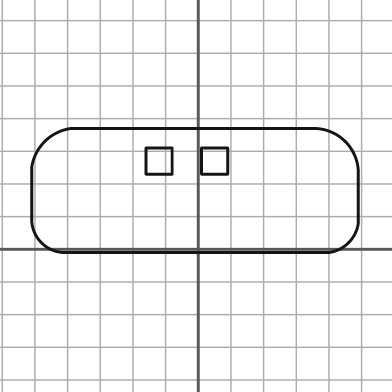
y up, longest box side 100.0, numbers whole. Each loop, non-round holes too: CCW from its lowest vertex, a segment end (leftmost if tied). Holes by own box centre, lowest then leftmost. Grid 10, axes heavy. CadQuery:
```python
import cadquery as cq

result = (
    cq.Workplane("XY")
    .moveTo(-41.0, -1.0)
    .lineTo(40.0, -1.0)
    .threePointArc((46.0, 2.0), (49.0, 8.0))
    .lineTo(49.0, 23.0)
    .threePointArc((45.0, 33.0), (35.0, 37.0))
    .lineTo(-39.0, 37.0)
    .threePointArc((-47.0, 33.0), (-51.0, 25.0))
    .lineTo(-51.0, 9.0)
    .threePointArc((-48.0, 2.0), (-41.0, -1.0))
    .close()
    .moveTo(-16.0, 23.0)
    .lineTo(-8.0, 23.0)
    .lineTo(-8.0, 31.0)
    .lineTo(-16.0, 31.0)
    .close()
    .moveTo(1.0, 23.0)
    .lineTo(9.0, 23.0)
    .lineTo(9.0, 31.0)
    .lineTo(1.0, 31.0)
    .close()
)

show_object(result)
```